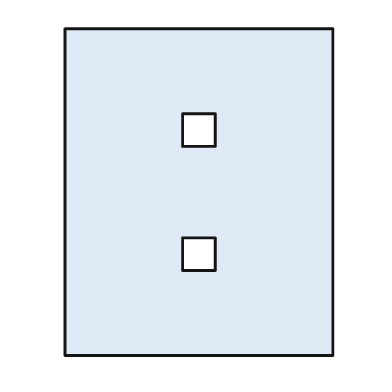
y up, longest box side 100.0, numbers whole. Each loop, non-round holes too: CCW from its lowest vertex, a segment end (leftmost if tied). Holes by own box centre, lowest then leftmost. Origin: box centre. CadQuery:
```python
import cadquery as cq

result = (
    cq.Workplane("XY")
    .moveTo(-41.0, -50.0)
    .lineTo(41.0, -50.0)
    .lineTo(41.0, 50.0)
    .lineTo(-41.0, 50.0)
    .close()
    .moveTo(-5.0, -24.0)
    .lineTo(5.0, -24.0)
    .lineTo(5.0, -14.0)
    .lineTo(-5.0, -14.0)
    .close()
    .moveTo(-5.0, 14.0)
    .lineTo(5.0, 14.0)
    .lineTo(5.0, 24.0)
    .lineTo(-5.0, 24.0)
    .close()
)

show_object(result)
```